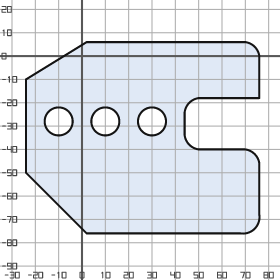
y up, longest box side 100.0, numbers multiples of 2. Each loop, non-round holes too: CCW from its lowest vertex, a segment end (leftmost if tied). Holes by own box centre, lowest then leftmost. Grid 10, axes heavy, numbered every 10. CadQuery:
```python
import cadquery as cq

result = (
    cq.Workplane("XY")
    .moveTo(2.0, -76.0)
    .lineTo(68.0, -76.0)
    .threePointArc((74.0, -74.0), (76.0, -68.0))
    .lineTo(76.0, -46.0)
    .threePointArc((74.0, -42.0), (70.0, -40.0))
    .lineTo(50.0, -40.0)
    .threePointArc((46.0, -38.0), (44.0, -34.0))
    .lineTo(44.0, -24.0)
    .threePointArc((46.0, -20.0), (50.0, -18.0))
    .lineTo(76.0, -18.0)
    .lineTo(76.0, 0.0)
    .threePointArc((74.0, 4.0), (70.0, 6.0))
    .lineTo(2.0, 6.0)
    .lineTo(-24.0, -10.0)
    .lineTo(-24.0, -50.0)
    .close()
    .moveTo(-10.0, -28.0)
    .circle(6.0)
    .moveTo(10.0, -28.0)
    .circle(6.0)
    .moveTo(30.0, -28.0)
    .circle(6.0)
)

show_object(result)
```